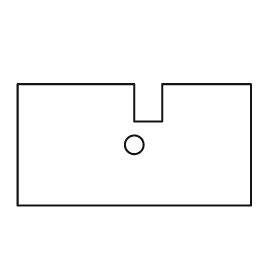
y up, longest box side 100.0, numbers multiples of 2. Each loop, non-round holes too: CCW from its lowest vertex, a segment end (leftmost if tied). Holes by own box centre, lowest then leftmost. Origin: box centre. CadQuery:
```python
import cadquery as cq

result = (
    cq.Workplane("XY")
    .moveTo(-50.0, -26.0)
    .lineTo(50.0, -26.0)
    .lineTo(50.0, 26.0)
    .lineTo(12.0, 26.0)
    .lineTo(12.0, 10.0)
    .lineTo(0.0, 10.0)
    .lineTo(0.0, 26.0)
    .lineTo(-50.0, 26.0)
    .close()
    .moveTo(0.0, 0.0)
    .circle(4.0)
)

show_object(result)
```